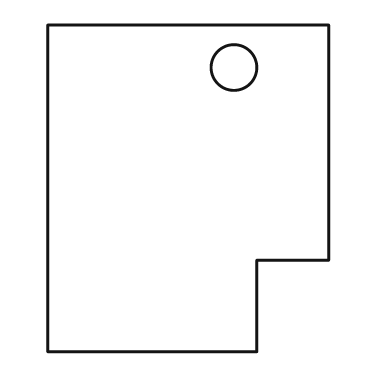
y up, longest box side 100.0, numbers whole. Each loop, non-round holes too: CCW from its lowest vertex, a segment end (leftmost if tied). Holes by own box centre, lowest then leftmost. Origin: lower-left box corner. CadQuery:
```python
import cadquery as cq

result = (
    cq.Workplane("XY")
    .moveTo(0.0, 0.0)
    .lineTo(64.0, 0.0)
    .lineTo(64.0, 28.0)
    .lineTo(86.0, 28.0)
    .lineTo(86.0, 100.0)
    .lineTo(0.0, 100.0)
    .close()
    .moveTo(57.0, 87.0)
    .circle(7.0)
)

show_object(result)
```